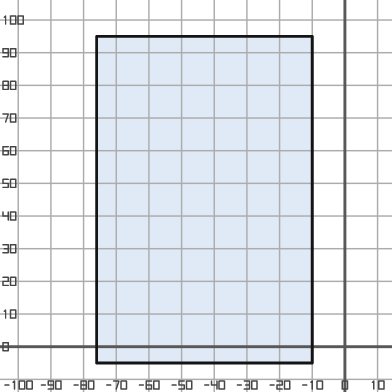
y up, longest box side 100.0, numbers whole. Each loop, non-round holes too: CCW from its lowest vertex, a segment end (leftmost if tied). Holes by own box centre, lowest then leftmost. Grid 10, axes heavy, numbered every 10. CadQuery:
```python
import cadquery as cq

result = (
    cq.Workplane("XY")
    .moveTo(-76.0, -5.0)
    .lineTo(-10.0, -5.0)
    .lineTo(-10.0, 95.0)
    .lineTo(-76.0, 95.0)
    .close()
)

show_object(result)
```